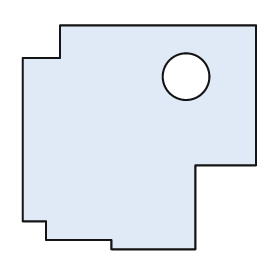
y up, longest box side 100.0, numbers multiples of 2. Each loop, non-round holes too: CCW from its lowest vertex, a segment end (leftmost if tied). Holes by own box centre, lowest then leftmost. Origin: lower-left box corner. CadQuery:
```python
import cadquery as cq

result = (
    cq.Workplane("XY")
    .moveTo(38.0, 0.0)
    .lineTo(74.0, 0.0)
    .lineTo(74.0, 36.0)
    .lineTo(100.0, 36.0)
    .lineTo(100.0, 96.0)
    .lineTo(16.0, 96.0)
    .lineTo(16.0, 82.0)
    .lineTo(0.0, 82.0)
    .lineTo(0.0, 12.0)
    .lineTo(10.0, 12.0)
    .lineTo(10.0, 4.0)
    .lineTo(38.0, 4.0)
    .close()
    .moveTo(70.0, 74.0)
    .circle(10.0)
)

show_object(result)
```